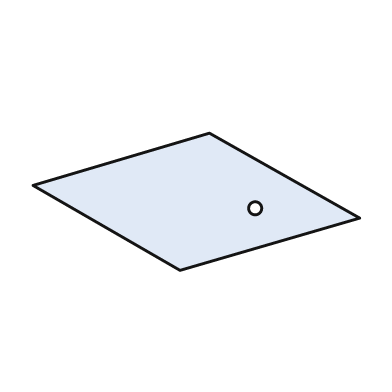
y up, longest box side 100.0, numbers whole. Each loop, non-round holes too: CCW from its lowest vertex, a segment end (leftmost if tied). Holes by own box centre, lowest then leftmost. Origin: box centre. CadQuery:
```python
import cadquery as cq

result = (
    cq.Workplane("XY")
    .moveTo(-5.0, -21.0)
    .lineTo(50.0, -5.0)
    .lineTo(4.0, 21.0)
    .lineTo(-50.0, 5.0)
    .close()
    .moveTo(18.0, -2.0)
    .circle(2.0)
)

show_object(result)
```